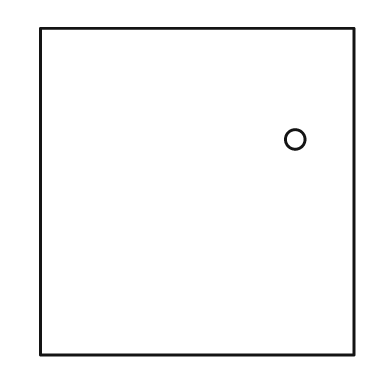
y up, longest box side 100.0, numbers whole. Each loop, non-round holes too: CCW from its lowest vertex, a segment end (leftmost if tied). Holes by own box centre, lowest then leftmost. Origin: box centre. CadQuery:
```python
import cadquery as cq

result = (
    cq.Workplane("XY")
    .moveTo(-48.0, -50.0)
    .lineTo(48.0, -50.0)
    .lineTo(48.0, 50.0)
    .lineTo(-48.0, 50.0)
    .close()
    .moveTo(30.0, 16.0)
    .circle(3.0)
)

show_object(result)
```